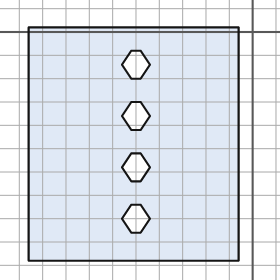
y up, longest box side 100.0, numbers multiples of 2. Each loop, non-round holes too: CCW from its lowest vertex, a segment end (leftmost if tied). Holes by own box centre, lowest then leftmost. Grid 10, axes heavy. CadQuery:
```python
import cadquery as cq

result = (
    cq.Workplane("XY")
    .moveTo(-96.0, -98.0)
    .lineTo(-6.0, -98.0)
    .lineTo(-6.0, 2.0)
    .lineTo(-96.0, 2.0)
    .close()
    .moveTo(-52.0, -86.0)
    .lineTo(-48.0, -86.0)
    .lineTo(-44.0, -80.0)
    .lineTo(-48.0, -74.0)
    .lineTo(-52.0, -74.0)
    .lineTo(-56.0, -80.0)
    .close()
    .moveTo(-52.0, -64.0)
    .lineTo(-48.0, -64.0)
    .lineTo(-44.0, -58.0)
    .lineTo(-48.0, -52.0)
    .lineTo(-52.0, -52.0)
    .lineTo(-56.0, -58.0)
    .close()
    .moveTo(-52.0, -42.0)
    .lineTo(-48.0, -42.0)
    .lineTo(-44.0, -36.0)
    .lineTo(-48.0, -30.0)
    .lineTo(-52.0, -30.0)
    .lineTo(-56.0, -36.0)
    .close()
    .moveTo(-52.0, -20.0)
    .lineTo(-48.0, -20.0)
    .lineTo(-44.0, -14.0)
    .lineTo(-48.0, -8.0)
    .lineTo(-52.0, -8.0)
    .lineTo(-56.0, -14.0)
    .close()
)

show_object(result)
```